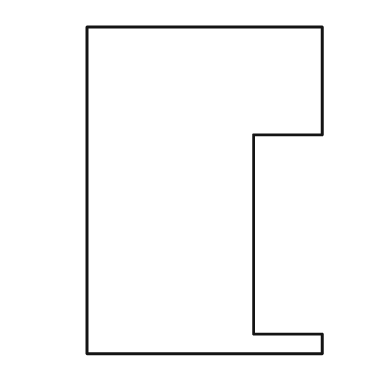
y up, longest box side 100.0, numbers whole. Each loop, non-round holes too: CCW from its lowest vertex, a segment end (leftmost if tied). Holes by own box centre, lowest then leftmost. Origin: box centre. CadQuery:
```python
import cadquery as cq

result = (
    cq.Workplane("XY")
    .moveTo(-36.0, -50.0)
    .lineTo(36.0, -50.0)
    .lineTo(36.0, -44.0)
    .lineTo(15.0, -44.0)
    .lineTo(15.0, 17.0)
    .lineTo(36.0, 17.0)
    .lineTo(36.0, 50.0)
    .lineTo(-36.0, 50.0)
    .close()
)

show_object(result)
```